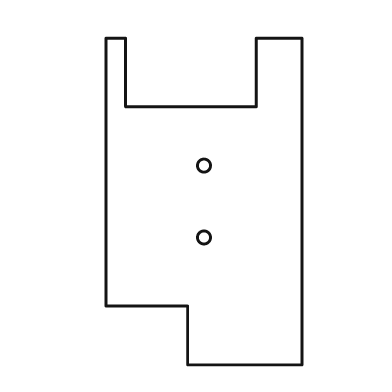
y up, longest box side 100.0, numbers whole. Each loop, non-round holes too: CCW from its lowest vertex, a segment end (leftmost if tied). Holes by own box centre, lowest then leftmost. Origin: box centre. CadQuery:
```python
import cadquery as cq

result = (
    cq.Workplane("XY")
    .moveTo(-5.0, -50.0)
    .lineTo(30.0, -50.0)
    .lineTo(30.0, 50.0)
    .lineTo(16.0, 50.0)
    .lineTo(16.0, 29.0)
    .lineTo(-24.0, 29.0)
    .lineTo(-24.0, 50.0)
    .lineTo(-30.0, 50.0)
    .lineTo(-30.0, -32.0)
    .lineTo(-5.0, -32.0)
    .close()
    .moveTo(0.0, -11.0)
    .circle(2.0)
    .moveTo(0.0, 11.0)
    .circle(2.0)
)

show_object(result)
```